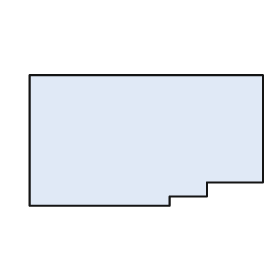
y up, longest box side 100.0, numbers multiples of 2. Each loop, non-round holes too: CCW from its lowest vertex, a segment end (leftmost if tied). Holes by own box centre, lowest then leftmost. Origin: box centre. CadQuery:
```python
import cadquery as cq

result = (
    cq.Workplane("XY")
    .moveTo(-50.0, -28.0)
    .lineTo(10.0, -28.0)
    .lineTo(10.0, -24.0)
    .lineTo(26.0, -24.0)
    .lineTo(26.0, -18.0)
    .lineTo(50.0, -18.0)
    .lineTo(50.0, 28.0)
    .lineTo(-50.0, 28.0)
    .close()
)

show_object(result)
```